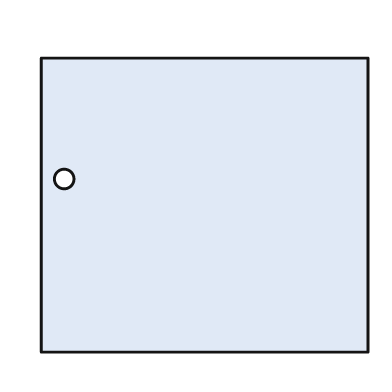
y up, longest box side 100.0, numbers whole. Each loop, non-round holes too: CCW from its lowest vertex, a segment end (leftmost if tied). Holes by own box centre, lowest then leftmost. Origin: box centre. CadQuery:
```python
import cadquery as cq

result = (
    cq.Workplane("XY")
    .moveTo(-50.0, -45.0)
    .lineTo(50.0, -45.0)
    .lineTo(50.0, 45.0)
    .lineTo(-50.0, 45.0)
    .close()
    .moveTo(-43.0, 8.0)
    .circle(3.0)
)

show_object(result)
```